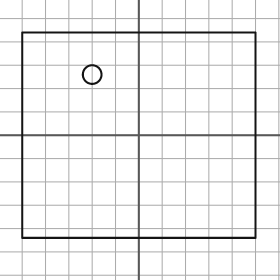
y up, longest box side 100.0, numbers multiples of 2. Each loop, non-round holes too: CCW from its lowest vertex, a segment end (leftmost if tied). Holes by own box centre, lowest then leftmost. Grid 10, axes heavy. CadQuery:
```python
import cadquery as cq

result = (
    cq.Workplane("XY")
    .moveTo(-50.0, -44.0)
    .lineTo(50.0, -44.0)
    .lineTo(50.0, 44.0)
    .lineTo(-50.0, 44.0)
    .close()
    .moveTo(-20.0, 26.0)
    .circle(4.0)
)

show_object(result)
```